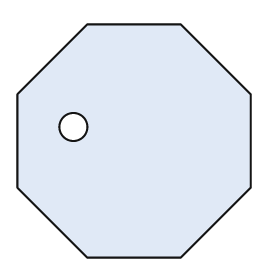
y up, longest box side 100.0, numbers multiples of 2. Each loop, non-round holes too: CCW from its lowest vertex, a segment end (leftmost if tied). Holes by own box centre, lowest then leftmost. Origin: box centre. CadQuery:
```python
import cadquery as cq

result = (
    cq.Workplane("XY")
    .moveTo(-20.0, -50.0)
    .lineTo(20.0, -50.0)
    .lineTo(50.0, -20.0)
    .lineTo(50.0, 20.0)
    .lineTo(20.0, 50.0)
    .lineTo(-20.0, 50.0)
    .lineTo(-50.0, 20.0)
    .lineTo(-50.0, -20.0)
    .close()
    .moveTo(-26.0, 6.0)
    .circle(6.0)
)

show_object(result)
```